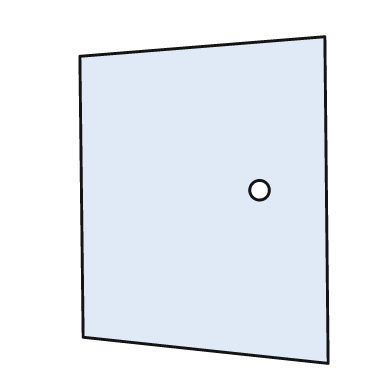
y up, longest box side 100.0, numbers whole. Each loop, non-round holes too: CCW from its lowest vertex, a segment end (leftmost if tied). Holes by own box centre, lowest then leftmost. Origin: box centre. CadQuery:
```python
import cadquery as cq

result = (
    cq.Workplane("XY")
    .moveTo(38.0, -50.0)
    .lineTo(37.0, 50.0)
    .lineTo(-38.0, 44.0)
    .lineTo(-37.0, -42.0)
    .close()
    .moveTo(17.0, 3.0)
    .circle(3.0)
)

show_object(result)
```